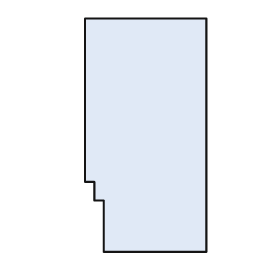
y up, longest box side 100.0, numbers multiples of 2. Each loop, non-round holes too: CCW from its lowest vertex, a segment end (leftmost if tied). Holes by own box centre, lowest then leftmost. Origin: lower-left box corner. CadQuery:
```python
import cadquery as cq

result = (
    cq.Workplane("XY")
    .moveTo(8.0, 0.0)
    .lineTo(52.0, 0.0)
    .lineTo(52.0, 100.0)
    .lineTo(0.0, 100.0)
    .lineTo(0.0, 30.0)
    .lineTo(4.0, 30.0)
    .lineTo(4.0, 22.0)
    .lineTo(8.0, 22.0)
    .close()
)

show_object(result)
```